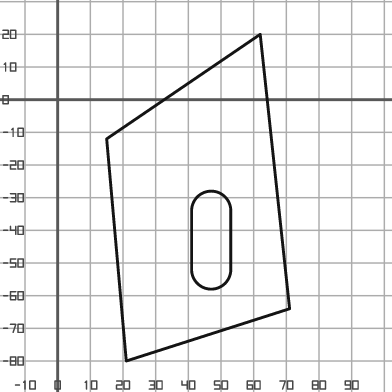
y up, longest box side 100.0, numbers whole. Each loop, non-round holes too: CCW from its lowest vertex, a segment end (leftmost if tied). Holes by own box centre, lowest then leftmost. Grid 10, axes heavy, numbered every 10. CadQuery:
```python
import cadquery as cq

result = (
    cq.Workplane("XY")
    .moveTo(21.0, -80.0)
    .lineTo(71.0, -64.0)
    .lineTo(62.0, 20.0)
    .lineTo(15.0, -12.0)
    .close()
    .moveTo(41.0, -52.0)
    .threePointArc((47.0, -58.0), (53.0, -52.0))
    .lineTo(53.0, -34.0)
    .threePointArc((47.0, -28.0), (41.0, -34.0))
    .close()
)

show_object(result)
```